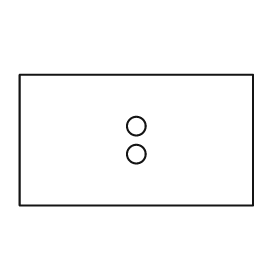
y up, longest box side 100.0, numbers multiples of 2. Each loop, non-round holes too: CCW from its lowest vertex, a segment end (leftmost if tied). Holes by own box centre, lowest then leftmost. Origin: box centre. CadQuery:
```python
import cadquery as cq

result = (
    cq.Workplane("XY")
    .moveTo(-50.0, -28.0)
    .lineTo(50.0, -28.0)
    .lineTo(50.0, 28.0)
    .lineTo(-50.0, 28.0)
    .close()
    .moveTo(0.0, -6.0)
    .circle(4.0)
    .moveTo(0.0, 6.0)
    .circle(4.0)
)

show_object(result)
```